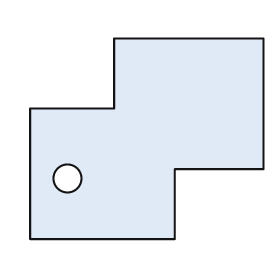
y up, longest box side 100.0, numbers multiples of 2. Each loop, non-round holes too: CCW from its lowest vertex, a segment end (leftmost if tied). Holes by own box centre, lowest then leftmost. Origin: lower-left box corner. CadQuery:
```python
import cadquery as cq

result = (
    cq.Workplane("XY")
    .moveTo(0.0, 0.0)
    .lineTo(62.0, 0.0)
    .lineTo(62.0, 30.0)
    .lineTo(100.0, 30.0)
    .lineTo(100.0, 86.0)
    .lineTo(36.0, 86.0)
    .lineTo(36.0, 56.0)
    .lineTo(0.0, 56.0)
    .close()
    .moveTo(16.0, 26.0)
    .circle(6.0)
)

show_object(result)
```